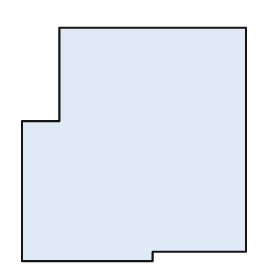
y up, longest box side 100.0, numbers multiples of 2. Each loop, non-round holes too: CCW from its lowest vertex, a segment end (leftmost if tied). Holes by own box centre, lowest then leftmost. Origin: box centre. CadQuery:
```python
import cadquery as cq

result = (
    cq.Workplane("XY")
    .moveTo(-48.0, -50.0)
    .lineTo(8.0, -50.0)
    .lineTo(8.0, -46.0)
    .lineTo(48.0, -46.0)
    .lineTo(48.0, 50.0)
    .lineTo(-32.0, 50.0)
    .lineTo(-32.0, 10.0)
    .lineTo(-48.0, 10.0)
    .close()
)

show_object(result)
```